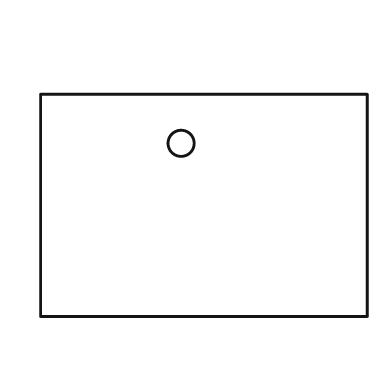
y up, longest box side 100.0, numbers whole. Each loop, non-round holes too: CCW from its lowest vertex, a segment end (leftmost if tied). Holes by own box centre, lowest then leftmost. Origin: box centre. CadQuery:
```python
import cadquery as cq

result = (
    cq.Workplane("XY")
    .moveTo(-50.0, -34.0)
    .lineTo(50.0, -34.0)
    .lineTo(50.0, 34.0)
    .lineTo(-50.0, 34.0)
    .close()
    .moveTo(-7.0, 19.0)
    .circle(4.0)
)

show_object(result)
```